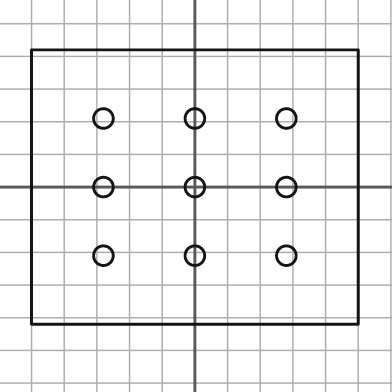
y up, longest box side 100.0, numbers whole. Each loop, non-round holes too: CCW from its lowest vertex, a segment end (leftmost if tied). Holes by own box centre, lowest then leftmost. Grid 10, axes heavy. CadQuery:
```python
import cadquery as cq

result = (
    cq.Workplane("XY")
    .moveTo(-50.0, -42.0)
    .lineTo(50.0, -42.0)
    .lineTo(50.0, 42.0)
    .lineTo(-50.0, 42.0)
    .close()
    .moveTo(-28.0, -21.0)
    .circle(3.0)
    .moveTo(0.0, -21.0)
    .circle(3.0)
    .moveTo(28.0, -21.0)
    .circle(3.0)
    .moveTo(-28.0, 0.0)
    .circle(3.0)
    .moveTo(0.0, 0.0)
    .circle(3.0)
    .moveTo(28.0, 0.0)
    .circle(3.0)
    .moveTo(-28.0, 21.0)
    .circle(3.0)
    .moveTo(0.0, 21.0)
    .circle(3.0)
    .moveTo(28.0, 21.0)
    .circle(3.0)
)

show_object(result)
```